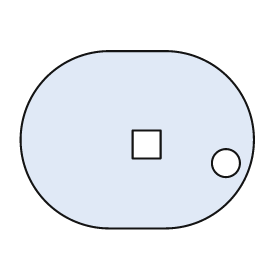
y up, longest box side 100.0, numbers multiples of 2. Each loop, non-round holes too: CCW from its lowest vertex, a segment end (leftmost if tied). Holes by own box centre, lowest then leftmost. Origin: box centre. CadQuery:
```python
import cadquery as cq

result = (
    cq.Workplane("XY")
    .moveTo(-12.0, -38.0)
    .lineTo(12.0, -38.0)
    .threePointArc((50.0, 0.0), (12.0, 38.0))
    .lineTo(-12.0, 38.0)
    .threePointArc((-50.0, 0.0), (-12.0, -38.0))
    .close()
    .moveTo(38.0, -10.0)
    .circle(6.0)
    .moveTo(-2.0, -8.0)
    .lineTo(10.0, -8.0)
    .lineTo(10.0, 4.0)
    .lineTo(-2.0, 4.0)
    .close()
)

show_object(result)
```